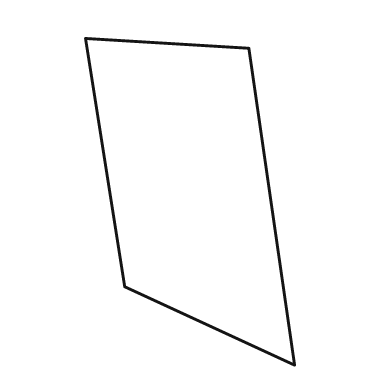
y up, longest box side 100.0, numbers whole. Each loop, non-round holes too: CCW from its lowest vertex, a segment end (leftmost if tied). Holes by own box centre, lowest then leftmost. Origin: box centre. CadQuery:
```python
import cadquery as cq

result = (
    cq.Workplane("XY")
    .moveTo(32.0, -50.0)
    .lineTo(18.0, 47.0)
    .lineTo(-32.0, 50.0)
    .lineTo(-20.0, -26.0)
    .close()
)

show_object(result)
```